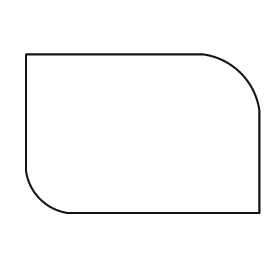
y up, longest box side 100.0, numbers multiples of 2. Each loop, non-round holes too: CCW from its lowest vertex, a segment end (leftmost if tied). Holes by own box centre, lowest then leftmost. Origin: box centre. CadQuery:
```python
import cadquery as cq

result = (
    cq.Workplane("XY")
    .moveTo(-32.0, -34.0)
    .lineTo(50.0, -34.0)
    .lineTo(50.0, 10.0)
    .threePointArc((42.0, 26.0), (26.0, 34.0))
    .lineTo(-50.0, 34.0)
    .lineTo(-50.0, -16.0)
    .threePointArc((-44.0, -28.0), (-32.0, -34.0))
    .close()
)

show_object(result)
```